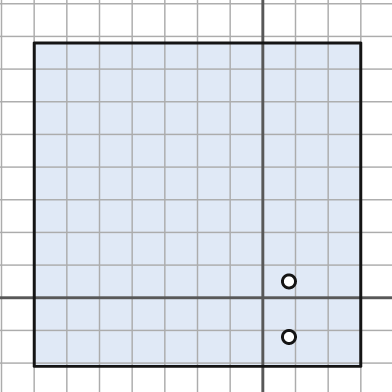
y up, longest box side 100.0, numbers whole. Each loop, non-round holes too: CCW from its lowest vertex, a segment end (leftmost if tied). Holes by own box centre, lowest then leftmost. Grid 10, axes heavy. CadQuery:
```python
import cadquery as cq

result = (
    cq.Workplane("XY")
    .moveTo(-70.0, -21.0)
    .lineTo(30.0, -21.0)
    .lineTo(30.0, 78.0)
    .lineTo(-70.0, 78.0)
    .close()
    .moveTo(8.0, -12.0)
    .circle(2.0)
    .moveTo(8.0, 5.0)
    .circle(2.0)
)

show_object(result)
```